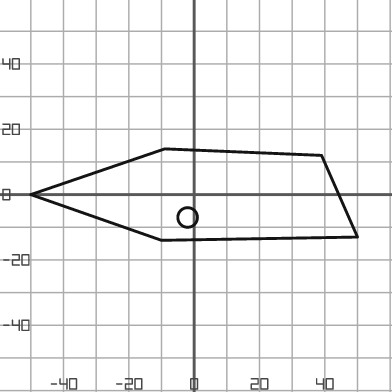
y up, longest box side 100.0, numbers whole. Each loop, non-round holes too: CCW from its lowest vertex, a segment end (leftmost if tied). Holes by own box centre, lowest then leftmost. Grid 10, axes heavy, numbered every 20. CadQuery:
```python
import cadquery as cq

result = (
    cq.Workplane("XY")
    .moveTo(-10.0, -14.0)
    .lineTo(50.0, -13.0)
    .lineTo(39.0, 12.0)
    .lineTo(-9.0, 14.0)
    .lineTo(-50.0, 0.0)
    .close()
    .moveTo(-2.0, -7.0)
    .circle(3.0)
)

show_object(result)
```